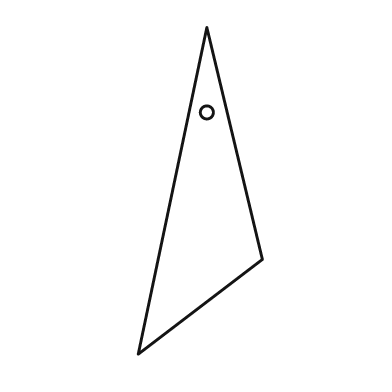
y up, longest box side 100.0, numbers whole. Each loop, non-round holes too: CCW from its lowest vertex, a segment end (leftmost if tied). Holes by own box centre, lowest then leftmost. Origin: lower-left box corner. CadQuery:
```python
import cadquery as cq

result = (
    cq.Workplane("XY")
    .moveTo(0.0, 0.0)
    .lineTo(38.0, 29.0)
    .lineTo(21.0, 100.0)
    .close()
    .moveTo(21.0, 74.0)
    .circle(2.0)
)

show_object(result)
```